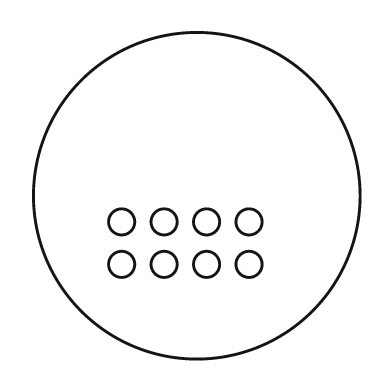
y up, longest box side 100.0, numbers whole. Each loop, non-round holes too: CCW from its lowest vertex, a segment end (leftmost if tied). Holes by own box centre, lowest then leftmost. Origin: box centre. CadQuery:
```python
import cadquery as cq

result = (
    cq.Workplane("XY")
    .moveTo(0.0, 0.0)
    .circle(50.0)
    .moveTo(-23.0, -21.0)
    .circle(4.0)
    .moveTo(-10.0, -21.0)
    .circle(4.0)
    .moveTo(3.0, -21.0)
    .circle(4.0)
    .moveTo(16.0, -21.0)
    .circle(4.0)
    .moveTo(-23.0, -8.0)
    .circle(4.0)
    .moveTo(-10.0, -8.0)
    .circle(4.0)
    .moveTo(3.0, -8.0)
    .circle(4.0)
    .moveTo(16.0, -8.0)
    .circle(4.0)
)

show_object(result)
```